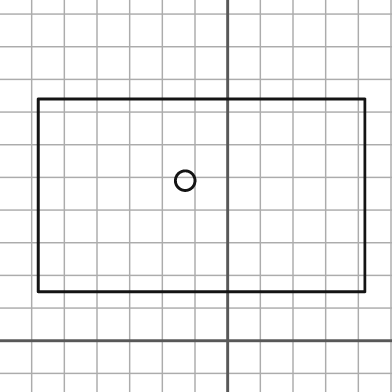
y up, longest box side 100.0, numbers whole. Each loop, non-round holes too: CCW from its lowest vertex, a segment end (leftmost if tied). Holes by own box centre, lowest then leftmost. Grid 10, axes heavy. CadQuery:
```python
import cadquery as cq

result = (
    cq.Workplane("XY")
    .moveTo(-58.0, 15.0)
    .lineTo(42.0, 15.0)
    .lineTo(42.0, 74.0)
    .lineTo(-58.0, 74.0)
    .close()
    .moveTo(-13.0, 49.0)
    .circle(3.0)
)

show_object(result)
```